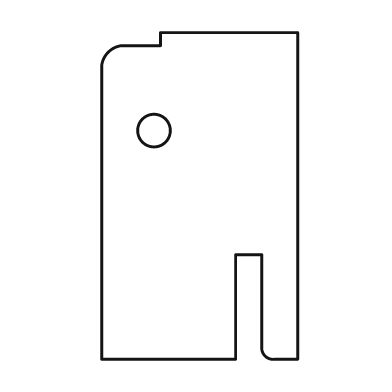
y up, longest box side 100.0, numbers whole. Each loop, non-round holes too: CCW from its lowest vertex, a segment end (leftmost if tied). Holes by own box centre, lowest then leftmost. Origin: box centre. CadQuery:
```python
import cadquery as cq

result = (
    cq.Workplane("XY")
    .moveTo(-30.0, -50.0)
    .lineTo(11.0, -50.0)
    .lineTo(11.0, -18.0)
    .lineTo(19.0, -18.0)
    .lineTo(19.0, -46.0)
    .threePointArc((20.0, -49.0), (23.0, -50.0))
    .lineTo(30.0, -50.0)
    .lineTo(30.0, 50.0)
    .lineTo(-12.0, 50.0)
    .lineTo(-12.0, 46.0)
    .lineTo(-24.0, 46.0)
    .threePointArc((-28.0, 44.0), (-30.0, 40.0))
    .close()
    .moveTo(-14.0, 20.0)
    .circle(5.0)
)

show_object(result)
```